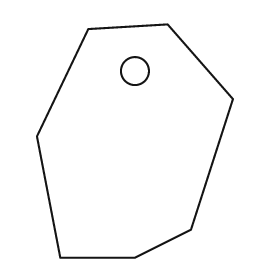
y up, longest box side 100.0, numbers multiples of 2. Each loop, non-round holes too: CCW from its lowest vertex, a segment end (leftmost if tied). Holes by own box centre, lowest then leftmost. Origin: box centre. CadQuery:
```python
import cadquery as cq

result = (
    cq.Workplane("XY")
    .moveTo(-32.0, -50.0)
    .lineTo(0.0, -50.0)
    .lineTo(24.0, -38.0)
    .lineTo(42.0, 18.0)
    .lineTo(14.0, 50.0)
    .lineTo(-20.0, 48.0)
    .lineTo(-42.0, 2.0)
    .close()
    .moveTo(0.0, 30.0)
    .circle(6.0)
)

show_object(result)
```